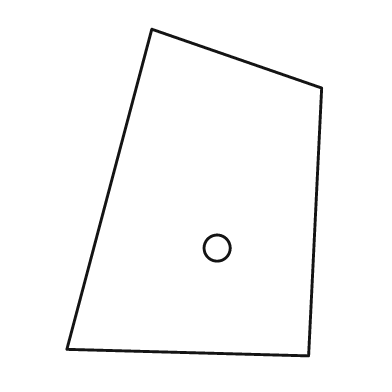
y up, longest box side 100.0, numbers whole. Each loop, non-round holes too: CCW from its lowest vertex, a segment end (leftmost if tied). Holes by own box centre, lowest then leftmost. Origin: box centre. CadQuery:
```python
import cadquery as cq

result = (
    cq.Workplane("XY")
    .moveTo(35.0, -50.0)
    .lineTo(39.0, 32.0)
    .lineTo(-13.0, 50.0)
    .lineTo(-39.0, -48.0)
    .close()
    .moveTo(7.0, -17.0)
    .circle(4.0)
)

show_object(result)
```